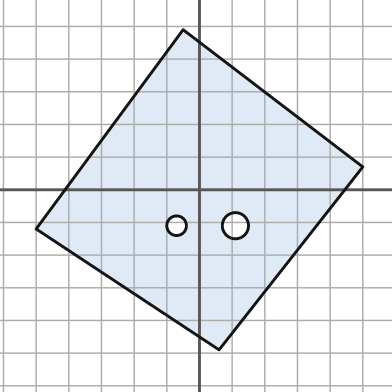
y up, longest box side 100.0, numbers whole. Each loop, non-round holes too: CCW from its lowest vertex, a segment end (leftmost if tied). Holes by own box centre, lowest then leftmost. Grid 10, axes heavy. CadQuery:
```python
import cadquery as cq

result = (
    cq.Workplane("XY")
    .moveTo(6.0, -49.0)
    .lineTo(50.0, 7.0)
    .lineTo(-5.0, 49.0)
    .lineTo(-50.0, -12.0)
    .close()
    .moveTo(-7.0, -11.0)
    .circle(3.0)
    .moveTo(11.0, -11.0)
    .circle(4.0)
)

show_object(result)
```